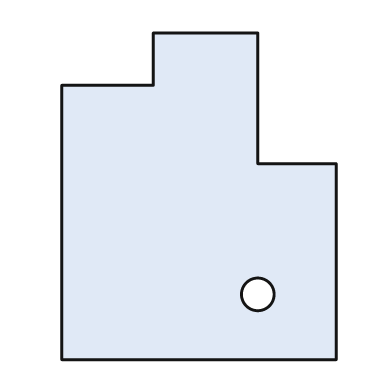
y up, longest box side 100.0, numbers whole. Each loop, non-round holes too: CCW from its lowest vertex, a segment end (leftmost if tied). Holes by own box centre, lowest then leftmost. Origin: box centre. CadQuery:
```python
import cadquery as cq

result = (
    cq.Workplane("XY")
    .moveTo(-42.0, -50.0)
    .lineTo(42.0, -50.0)
    .lineTo(42.0, 10.0)
    .lineTo(18.0, 10.0)
    .lineTo(18.0, 50.0)
    .lineTo(-14.0, 50.0)
    .lineTo(-14.0, 34.0)
    .lineTo(-42.0, 34.0)
    .close()
    .moveTo(18.0, -30.0)
    .circle(5.0)
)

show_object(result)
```